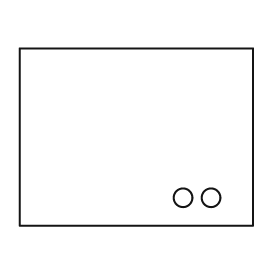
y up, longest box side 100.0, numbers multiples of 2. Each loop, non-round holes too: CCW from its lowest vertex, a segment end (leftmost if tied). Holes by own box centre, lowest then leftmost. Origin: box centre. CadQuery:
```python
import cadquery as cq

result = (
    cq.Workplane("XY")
    .moveTo(-50.0, -38.0)
    .lineTo(50.0, -38.0)
    .lineTo(50.0, 38.0)
    .lineTo(-50.0, 38.0)
    .close()
    .moveTo(20.0, -26.0)
    .circle(4.0)
    .moveTo(32.0, -26.0)
    .circle(4.0)
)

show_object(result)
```